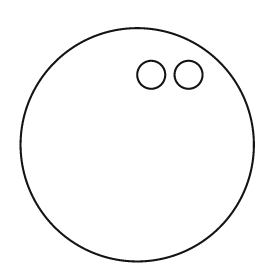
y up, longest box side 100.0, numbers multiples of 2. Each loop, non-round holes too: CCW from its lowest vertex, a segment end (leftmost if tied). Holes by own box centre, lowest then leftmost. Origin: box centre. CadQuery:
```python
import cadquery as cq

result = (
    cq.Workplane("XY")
    .moveTo(0.0, 0.0)
    .circle(50.0)
    .moveTo(6.0, 30.0)
    .circle(6.0)
    .moveTo(22.0, 30.0)
    .circle(6.0)
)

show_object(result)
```